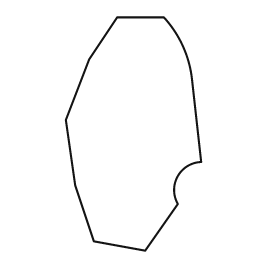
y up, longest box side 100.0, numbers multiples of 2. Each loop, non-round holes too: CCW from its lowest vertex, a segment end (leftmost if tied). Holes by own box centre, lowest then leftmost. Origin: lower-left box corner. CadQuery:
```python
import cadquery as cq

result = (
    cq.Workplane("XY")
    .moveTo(34.0, 0.0)
    .lineTo(48.0, 20.0)
    .threePointArc((48.0, 32.0), (58.0, 38.0))
    .lineTo(54.0, 74.0)
    .threePointArc((50.0, 88.0), (42.0, 100.0))
    .lineTo(22.0, 100.0)
    .lineTo(10.0, 82.0)
    .lineTo(0.0, 56.0)
    .lineTo(4.0, 28.0)
    .lineTo(12.0, 4.0)
    .close()
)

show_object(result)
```